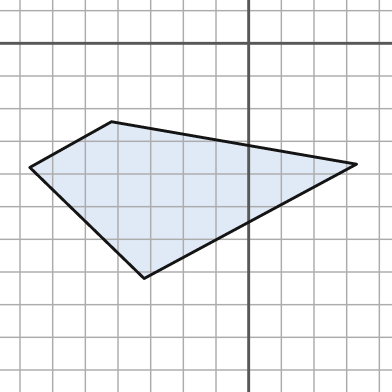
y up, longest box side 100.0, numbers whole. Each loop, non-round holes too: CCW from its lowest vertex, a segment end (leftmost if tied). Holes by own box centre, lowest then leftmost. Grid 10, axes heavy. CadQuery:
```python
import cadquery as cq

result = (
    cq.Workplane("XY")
    .moveTo(-32.0, -72.0)
    .lineTo(33.0, -37.0)
    .lineTo(-42.0, -24.0)
    .lineTo(-67.0, -38.0)
    .close()
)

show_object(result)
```